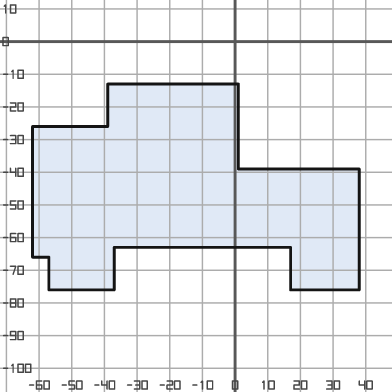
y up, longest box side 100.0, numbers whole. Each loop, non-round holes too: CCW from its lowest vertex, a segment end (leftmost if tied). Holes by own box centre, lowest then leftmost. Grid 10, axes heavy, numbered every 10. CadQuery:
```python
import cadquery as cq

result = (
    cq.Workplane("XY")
    .moveTo(-57.0, -76.0)
    .lineTo(-37.0, -76.0)
    .lineTo(-37.0, -63.0)
    .lineTo(17.0, -63.0)
    .lineTo(17.0, -76.0)
    .lineTo(38.0, -76.0)
    .lineTo(38.0, -39.0)
    .lineTo(1.0, -39.0)
    .lineTo(1.0, -13.0)
    .lineTo(-39.0, -13.0)
    .lineTo(-39.0, -26.0)
    .lineTo(-62.0, -26.0)
    .lineTo(-62.0, -66.0)
    .lineTo(-57.0, -66.0)
    .close()
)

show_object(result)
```